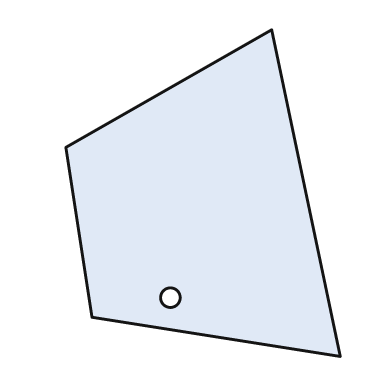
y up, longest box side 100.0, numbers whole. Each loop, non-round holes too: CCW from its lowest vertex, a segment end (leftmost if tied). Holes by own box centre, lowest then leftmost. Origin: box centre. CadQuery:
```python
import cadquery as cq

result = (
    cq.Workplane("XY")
    .moveTo(42.0, -50.0)
    .lineTo(21.0, 50.0)
    .lineTo(-42.0, 14.0)
    .lineTo(-34.0, -38.0)
    .close()
    .moveTo(-10.0, -32.0)
    .circle(3.0)
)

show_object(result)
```